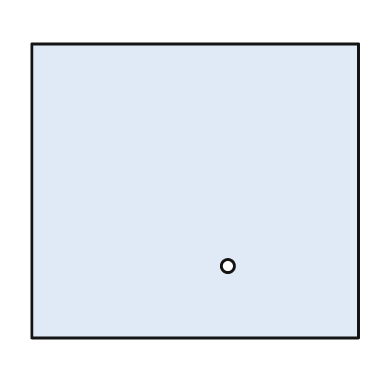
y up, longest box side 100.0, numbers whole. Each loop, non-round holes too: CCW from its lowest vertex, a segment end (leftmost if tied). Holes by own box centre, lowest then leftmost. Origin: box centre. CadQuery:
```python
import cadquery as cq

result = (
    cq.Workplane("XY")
    .moveTo(-50.0, -45.0)
    .lineTo(50.0, -45.0)
    .lineTo(50.0, 45.0)
    .lineTo(-50.0, 45.0)
    .close()
    .moveTo(10.0, -23.0)
    .circle(2.0)
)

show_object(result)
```